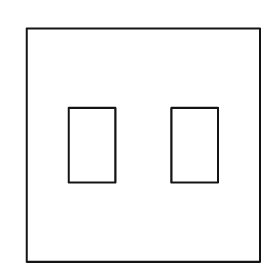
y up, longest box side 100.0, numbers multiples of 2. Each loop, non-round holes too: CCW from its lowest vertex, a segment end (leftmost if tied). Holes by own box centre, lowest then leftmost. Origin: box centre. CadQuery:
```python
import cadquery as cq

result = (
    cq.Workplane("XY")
    .moveTo(-50.0, -50.0)
    .lineTo(50.0, -50.0)
    .lineTo(50.0, 50.0)
    .lineTo(-50.0, 50.0)
    .close()
    .moveTo(-32.0, -16.0)
    .lineTo(-12.0, -16.0)
    .lineTo(-12.0, 16.0)
    .lineTo(-32.0, 16.0)
    .close()
    .moveTo(12.0, -16.0)
    .lineTo(32.0, -16.0)
    .lineTo(32.0, 16.0)
    .lineTo(12.0, 16.0)
    .close()
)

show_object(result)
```